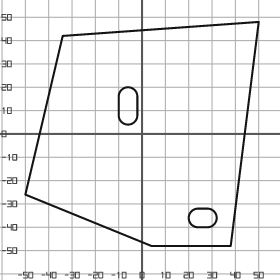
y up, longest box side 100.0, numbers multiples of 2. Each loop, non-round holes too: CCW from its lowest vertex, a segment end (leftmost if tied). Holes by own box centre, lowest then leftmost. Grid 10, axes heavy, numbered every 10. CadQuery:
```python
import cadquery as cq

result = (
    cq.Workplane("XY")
    .moveTo(4.0, -48.0)
    .lineTo(38.0, -48.0)
    .lineTo(50.0, 48.0)
    .lineTo(-34.0, 42.0)
    .lineTo(-50.0, -26.0)
    .close()
    .moveTo(24.0, -40.0)
    .lineTo(28.0, -40.0)
    .threePointArc((32.0, -36.0), (28.0, -32.0))
    .lineTo(24.0, -32.0)
    .threePointArc((20.0, -36.0), (24.0, -40.0))
    .close()
    .moveTo(-10.0, 8.0)
    .threePointArc((-6.0, 4.0), (-2.0, 8.0))
    .lineTo(-2.0, 16.0)
    .threePointArc((-6.0, 20.0), (-10.0, 16.0))
    .close()
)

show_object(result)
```